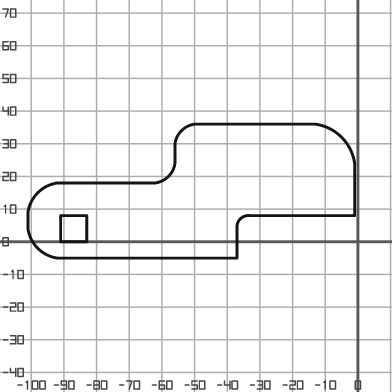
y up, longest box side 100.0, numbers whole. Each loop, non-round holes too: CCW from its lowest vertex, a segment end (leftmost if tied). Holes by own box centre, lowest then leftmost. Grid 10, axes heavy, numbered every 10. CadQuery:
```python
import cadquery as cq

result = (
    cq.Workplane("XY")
    .moveTo(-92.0, -5.0)
    .lineTo(-37.0, -5.0)
    .lineTo(-37.0, 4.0)
    .threePointArc((-36.0, 7.0), (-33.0, 8.0))
    .lineTo(-1.0, 8.0)
    .lineTo(-1.0, 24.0)
    .threePointArc((-5.0, 32.0), (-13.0, 36.0))
    .lineTo(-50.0, 36.0)
    .threePointArc((-54.0, 34.0), (-56.0, 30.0))
    .lineTo(-56.0, 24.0)
    .threePointArc((-58.0, 20.0), (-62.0, 18.0))
    .lineTo(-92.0, 18.0)
    .threePointArc((-98.0, 15.0), (-101.0, 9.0))
    .lineTo(-101.0, 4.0)
    .threePointArc((-98.0, -2.0), (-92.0, -5.0))
    .close()
    .moveTo(-91.0, 0.0)
    .lineTo(-83.0, 0.0)
    .lineTo(-83.0, 8.0)
    .lineTo(-91.0, 8.0)
    .close()
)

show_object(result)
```